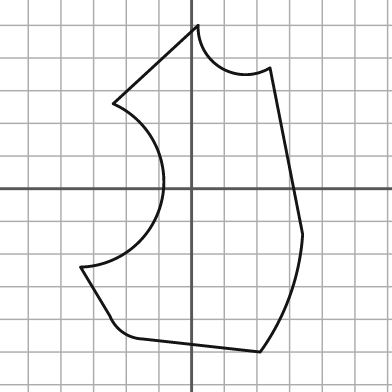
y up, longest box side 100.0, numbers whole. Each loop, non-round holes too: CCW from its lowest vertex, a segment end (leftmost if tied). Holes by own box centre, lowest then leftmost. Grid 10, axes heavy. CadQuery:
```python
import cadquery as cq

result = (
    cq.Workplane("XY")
    .moveTo(21.0, -50.0)
    .threePointArc((30.0, -33.0), (34.0, -14.0))
    .lineTo(24.0, 37.0)
    .threePointArc((9.0, 37.0), (2.0, 50.0))
    .lineTo(-24.0, 26.0)
    .threePointArc((-9.0, -3.0), (-34.0, -24.0))
    .lineTo(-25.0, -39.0)
    .threePointArc((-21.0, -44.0), (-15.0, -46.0))
    .close()
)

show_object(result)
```